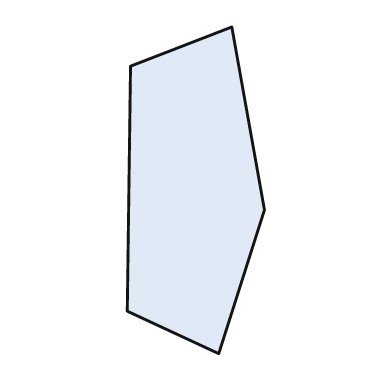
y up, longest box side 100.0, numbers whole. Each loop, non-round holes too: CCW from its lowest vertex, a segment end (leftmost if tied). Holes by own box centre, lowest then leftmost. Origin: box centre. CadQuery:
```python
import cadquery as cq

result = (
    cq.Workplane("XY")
    .moveTo(7.0, -50.0)
    .lineTo(21.0, -6.0)
    .lineTo(11.0, 50.0)
    .lineTo(-20.0, 38.0)
    .lineTo(-21.0, -37.0)
    .close()
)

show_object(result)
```